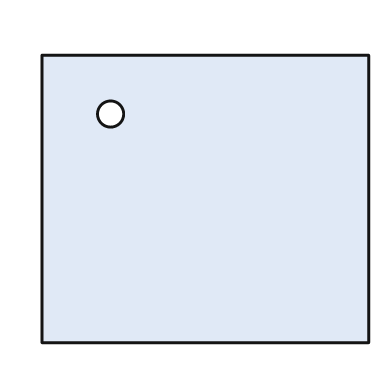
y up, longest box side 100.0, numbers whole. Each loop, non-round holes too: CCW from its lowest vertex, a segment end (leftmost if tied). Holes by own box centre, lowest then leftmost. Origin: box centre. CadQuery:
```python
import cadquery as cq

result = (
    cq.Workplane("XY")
    .moveTo(-50.0, -44.0)
    .lineTo(50.0, -44.0)
    .lineTo(50.0, 44.0)
    .lineTo(-50.0, 44.0)
    .close()
    .moveTo(-29.0, 26.0)
    .circle(4.0)
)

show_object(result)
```